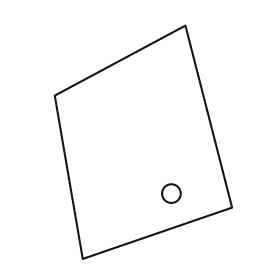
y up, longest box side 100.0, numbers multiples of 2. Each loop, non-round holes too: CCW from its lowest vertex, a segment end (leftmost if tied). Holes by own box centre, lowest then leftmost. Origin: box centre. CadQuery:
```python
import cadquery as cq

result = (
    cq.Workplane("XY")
    .moveTo(-26.0, -50.0)
    .lineTo(38.0, -28.0)
    .lineTo(18.0, 50.0)
    .lineTo(-38.0, 20.0)
    .close()
    .moveTo(12.0, -22.0)
    .circle(4.0)
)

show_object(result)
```